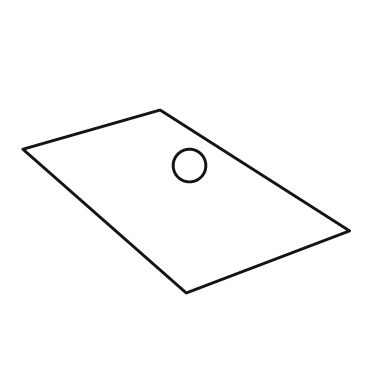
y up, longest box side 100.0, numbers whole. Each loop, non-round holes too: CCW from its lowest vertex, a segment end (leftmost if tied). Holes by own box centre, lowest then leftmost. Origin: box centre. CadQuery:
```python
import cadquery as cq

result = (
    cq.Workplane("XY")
    .moveTo(0.0, -28.0)
    .lineTo(50.0, -9.0)
    .lineTo(-8.0, 28.0)
    .lineTo(-50.0, 16.0)
    .close()
    .moveTo(1.0, 11.0)
    .circle(5.0)
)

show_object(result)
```